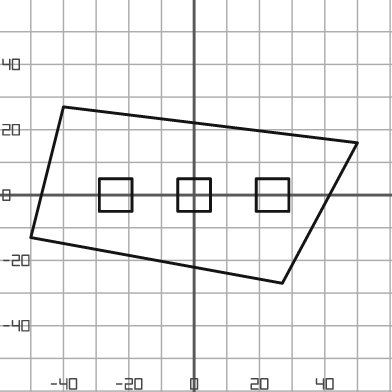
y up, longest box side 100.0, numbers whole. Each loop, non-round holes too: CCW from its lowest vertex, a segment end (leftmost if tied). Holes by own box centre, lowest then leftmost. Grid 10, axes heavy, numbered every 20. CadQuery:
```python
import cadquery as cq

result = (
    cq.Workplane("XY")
    .moveTo(27.0, -27.0)
    .lineTo(50.0, 16.0)
    .lineTo(-40.0, 27.0)
    .lineTo(-50.0, -13.0)
    .close()
    .moveTo(-29.0, -5.0)
    .lineTo(-19.0, -5.0)
    .lineTo(-19.0, 5.0)
    .lineTo(-29.0, 5.0)
    .close()
    .moveTo(-5.0, -5.0)
    .lineTo(5.0, -5.0)
    .lineTo(5.0, 5.0)
    .lineTo(-5.0, 5.0)
    .close()
    .moveTo(19.0, -5.0)
    .lineTo(29.0, -5.0)
    .lineTo(29.0, 5.0)
    .lineTo(19.0, 5.0)
    .close()
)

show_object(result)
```